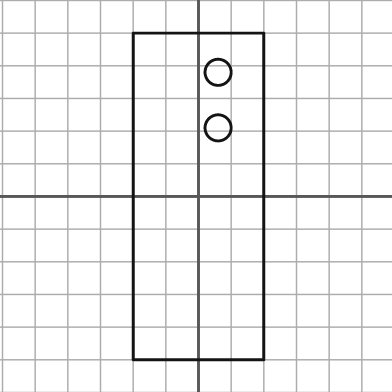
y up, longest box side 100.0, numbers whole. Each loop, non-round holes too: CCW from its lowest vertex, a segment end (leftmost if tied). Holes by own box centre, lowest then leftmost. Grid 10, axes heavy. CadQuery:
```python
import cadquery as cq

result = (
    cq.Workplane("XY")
    .moveTo(-20.0, -50.0)
    .lineTo(20.0, -50.0)
    .lineTo(20.0, 50.0)
    .lineTo(-20.0, 50.0)
    .close()
    .moveTo(6.0, 21.0)
    .circle(4.0)
    .moveTo(6.0, 38.0)
    .circle(4.0)
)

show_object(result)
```